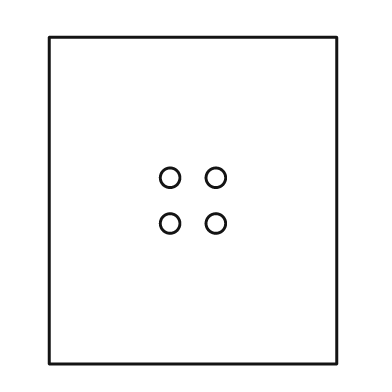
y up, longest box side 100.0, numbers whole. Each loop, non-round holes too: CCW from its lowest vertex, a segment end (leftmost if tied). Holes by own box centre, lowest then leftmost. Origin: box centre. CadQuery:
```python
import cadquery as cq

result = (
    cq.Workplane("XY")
    .moveTo(-44.0, -50.0)
    .lineTo(44.0, -50.0)
    .lineTo(44.0, 50.0)
    .lineTo(-44.0, 50.0)
    .close()
    .moveTo(-7.0, -7.0)
    .circle(3.0)
    .moveTo(7.0, -7.0)
    .circle(3.0)
    .moveTo(-7.0, 7.0)
    .circle(3.0)
    .moveTo(7.0, 7.0)
    .circle(3.0)
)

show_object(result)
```